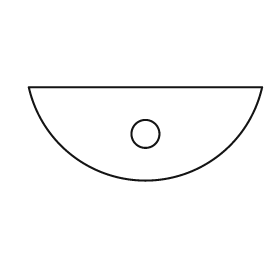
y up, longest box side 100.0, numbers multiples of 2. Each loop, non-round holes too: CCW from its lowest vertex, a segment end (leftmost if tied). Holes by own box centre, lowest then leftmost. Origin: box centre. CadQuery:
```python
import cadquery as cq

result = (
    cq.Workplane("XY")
    .moveTo(-50.0, 20.0)
    .threePointArc((0.0, -20.0), (50.0, 20.0))
    .close()
    .moveTo(0.0, 0.0)
    .circle(6.0)
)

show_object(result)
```